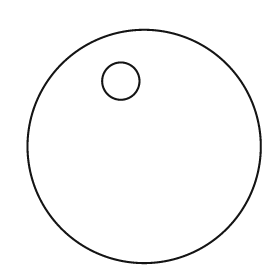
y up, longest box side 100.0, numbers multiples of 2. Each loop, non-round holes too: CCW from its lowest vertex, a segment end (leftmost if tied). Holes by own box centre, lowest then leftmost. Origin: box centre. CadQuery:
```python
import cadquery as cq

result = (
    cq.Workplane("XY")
    .moveTo(0.0, 0.0)
    .circle(50.0)
    .moveTo(-10.0, 28.0)
    .circle(8.0)
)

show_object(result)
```